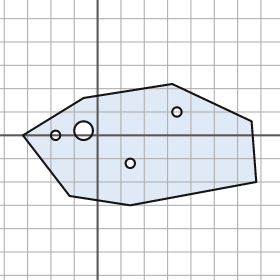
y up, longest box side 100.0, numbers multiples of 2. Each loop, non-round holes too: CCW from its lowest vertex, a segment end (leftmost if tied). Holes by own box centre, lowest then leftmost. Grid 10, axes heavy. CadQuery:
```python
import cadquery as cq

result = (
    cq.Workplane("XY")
    .moveTo(14.0, -30.0)
    .lineTo(68.0, -20.0)
    .lineTo(66.0, 6.0)
    .lineTo(32.0, 22.0)
    .lineTo(-6.0, 16.0)
    .lineTo(-32.0, 0.0)
    .lineTo(-12.0, -26.0)
    .close()
    .moveTo(14.0, -12.0)
    .circle(2.0)
    .moveTo(-18.0, 0.0)
    .circle(2.0)
    .moveTo(-6.0, 2.0)
    .circle(4.0)
    .moveTo(34.0, 10.0)
    .circle(2.0)
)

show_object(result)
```